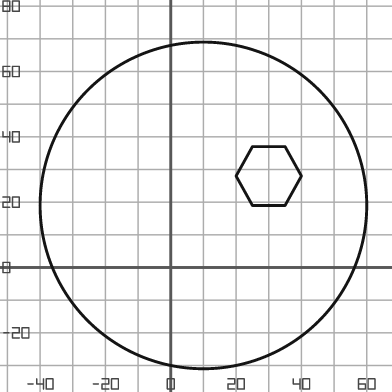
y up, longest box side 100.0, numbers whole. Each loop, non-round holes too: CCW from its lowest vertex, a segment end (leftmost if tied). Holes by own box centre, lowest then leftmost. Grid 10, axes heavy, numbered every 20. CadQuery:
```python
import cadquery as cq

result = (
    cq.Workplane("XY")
    .moveTo(10.0, 19.0)
    .circle(50.0)
    .moveTo(25.0, 19.0)
    .lineTo(35.0, 19.0)
    .lineTo(40.0, 28.0)
    .lineTo(35.0, 37.0)
    .lineTo(25.0, 37.0)
    .lineTo(20.0, 28.0)
    .close()
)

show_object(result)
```